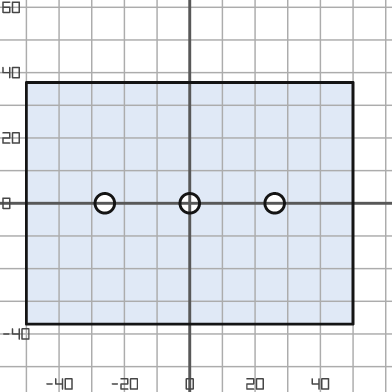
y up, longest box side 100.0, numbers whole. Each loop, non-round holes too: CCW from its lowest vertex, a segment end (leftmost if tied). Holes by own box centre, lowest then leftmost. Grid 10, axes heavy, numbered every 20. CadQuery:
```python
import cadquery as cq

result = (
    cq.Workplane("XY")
    .moveTo(-50.0, -37.0)
    .lineTo(50.0, -37.0)
    .lineTo(50.0, 37.0)
    .lineTo(-50.0, 37.0)
    .close()
    .moveTo(-26.0, 0.0)
    .circle(3.0)
    .moveTo(0.0, 0.0)
    .circle(3.0)
    .moveTo(26.0, 0.0)
    .circle(3.0)
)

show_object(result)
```